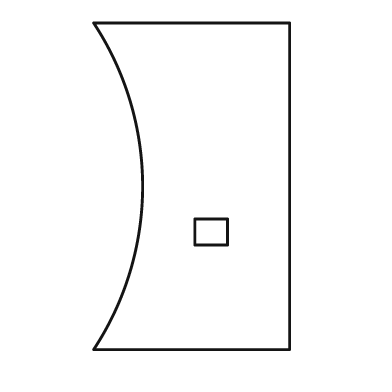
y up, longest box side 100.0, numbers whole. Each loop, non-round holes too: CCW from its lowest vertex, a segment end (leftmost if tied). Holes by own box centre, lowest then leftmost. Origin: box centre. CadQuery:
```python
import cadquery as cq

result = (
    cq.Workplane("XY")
    .moveTo(-30.0, -50.0)
    .lineTo(30.0, -50.0)
    .lineTo(30.0, 50.0)
    .lineTo(-30.0, 50.0)
    .threePointArc((-15.0, 0.0), (-30.0, -50.0))
    .close()
    .moveTo(1.0, -18.0)
    .lineTo(11.0, -18.0)
    .lineTo(11.0, -10.0)
    .lineTo(1.0, -10.0)
    .close()
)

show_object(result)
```